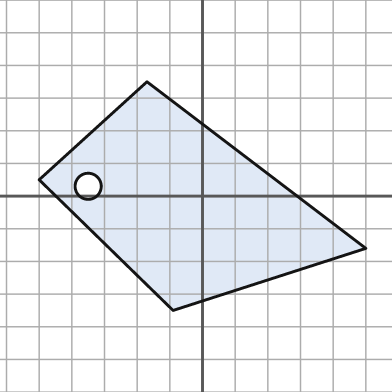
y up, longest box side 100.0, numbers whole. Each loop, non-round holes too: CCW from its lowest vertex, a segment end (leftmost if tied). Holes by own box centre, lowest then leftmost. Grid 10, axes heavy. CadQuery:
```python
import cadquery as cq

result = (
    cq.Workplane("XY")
    .moveTo(-9.0, -35.0)
    .lineTo(50.0, -16.0)
    .lineTo(-17.0, 35.0)
    .lineTo(-50.0, 5.0)
    .close()
    .moveTo(-35.0, 3.0)
    .circle(4.0)
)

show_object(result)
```